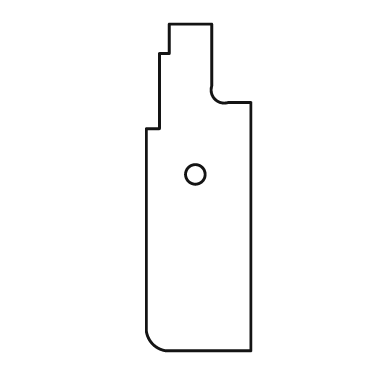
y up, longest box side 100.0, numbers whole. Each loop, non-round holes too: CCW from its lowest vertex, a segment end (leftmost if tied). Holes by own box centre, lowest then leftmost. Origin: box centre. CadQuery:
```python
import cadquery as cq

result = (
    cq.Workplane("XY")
    .moveTo(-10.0, -50.0)
    .lineTo(16.0, -50.0)
    .lineTo(16.0, 26.0)
    .lineTo(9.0, 26.0)
    .threePointArc((5.0, 27.0), (4.0, 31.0))
    .lineTo(4.0, 50.0)
    .lineTo(-9.0, 50.0)
    .lineTo(-9.0, 41.0)
    .lineTo(-12.0, 41.0)
    .lineTo(-12.0, 18.0)
    .lineTo(-16.0, 18.0)
    .lineTo(-16.0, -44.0)
    .threePointArc((-14.0, -48.0), (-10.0, -50.0))
    .close()
    .moveTo(-1.0, 4.0)
    .circle(3.0)
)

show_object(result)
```